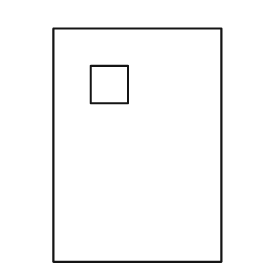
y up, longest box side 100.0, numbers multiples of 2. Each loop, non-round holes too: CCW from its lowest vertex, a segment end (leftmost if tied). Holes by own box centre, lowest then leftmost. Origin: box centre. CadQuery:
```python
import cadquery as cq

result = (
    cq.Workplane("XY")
    .moveTo(-36.0, -50.0)
    .lineTo(36.0, -50.0)
    .lineTo(36.0, 50.0)
    .lineTo(-36.0, 50.0)
    .close()
    .moveTo(-20.0, 18.0)
    .lineTo(-4.0, 18.0)
    .lineTo(-4.0, 34.0)
    .lineTo(-20.0, 34.0)
    .close()
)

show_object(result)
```